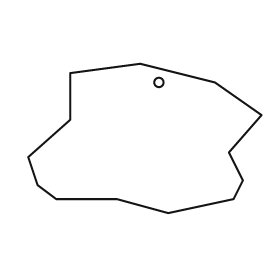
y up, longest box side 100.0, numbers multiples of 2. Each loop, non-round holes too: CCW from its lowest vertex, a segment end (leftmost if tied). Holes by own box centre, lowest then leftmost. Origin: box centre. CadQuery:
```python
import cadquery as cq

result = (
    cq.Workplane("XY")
    .moveTo(10.0, -32.0)
    .lineTo(38.0, -26.0)
    .lineTo(42.0, -18.0)
    .lineTo(36.0, -6.0)
    .lineTo(50.0, 10.0)
    .lineTo(30.0, 24.0)
    .lineTo(-2.0, 32.0)
    .lineTo(-32.0, 28.0)
    .lineTo(-32.0, 8.0)
    .lineTo(-50.0, -8.0)
    .lineTo(-46.0, -20.0)
    .lineTo(-38.0, -26.0)
    .lineTo(-12.0, -26.0)
    .close()
    .moveTo(6.0, 24.0)
    .circle(2.0)
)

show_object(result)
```